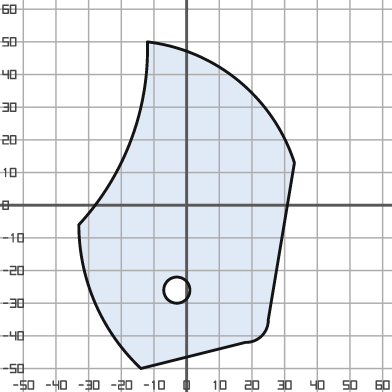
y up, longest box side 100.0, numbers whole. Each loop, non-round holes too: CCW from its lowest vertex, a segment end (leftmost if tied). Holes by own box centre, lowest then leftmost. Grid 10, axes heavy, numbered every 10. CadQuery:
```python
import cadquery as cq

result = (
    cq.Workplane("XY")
    .moveTo(-14.0, -50.0)
    .lineTo(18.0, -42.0)
    .threePointArc((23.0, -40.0), (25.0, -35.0))
    .lineTo(33.0, 13.0)
    .threePointArc((16.0, 38.0), (-12.0, 50.0))
    .threePointArc((-17.0, 20.0), (-33.0, -6.0))
    .threePointArc((-28.0, -30.0), (-14.0, -50.0))
    .close()
    .moveTo(-3.0, -26.0)
    .circle(4.0)
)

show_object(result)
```